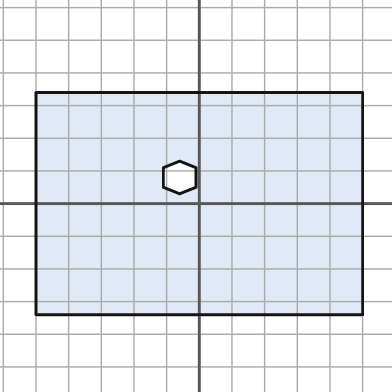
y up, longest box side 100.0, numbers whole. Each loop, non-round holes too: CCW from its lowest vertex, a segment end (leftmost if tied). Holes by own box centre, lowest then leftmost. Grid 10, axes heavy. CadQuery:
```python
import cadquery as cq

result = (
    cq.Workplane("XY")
    .moveTo(-50.0, -34.0)
    .lineTo(50.0, -34.0)
    .lineTo(50.0, 34.0)
    .lineTo(-50.0, 34.0)
    .close()
    .moveTo(-6.0, 3.0)
    .lineTo(-1.0, 5.0)
    .lineTo(-1.0, 11.0)
    .lineTo(-6.0, 13.0)
    .lineTo(-11.0, 11.0)
    .lineTo(-11.0, 5.0)
    .close()
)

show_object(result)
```